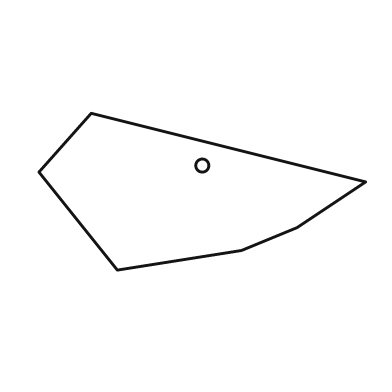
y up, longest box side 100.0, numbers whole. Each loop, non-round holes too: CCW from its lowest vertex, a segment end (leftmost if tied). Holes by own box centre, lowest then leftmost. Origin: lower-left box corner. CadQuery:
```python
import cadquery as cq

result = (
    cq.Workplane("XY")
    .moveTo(24.0, 0.0)
    .lineTo(62.0, 6.0)
    .lineTo(79.0, 13.0)
    .lineTo(100.0, 27.0)
    .lineTo(16.0, 48.0)
    .lineTo(0.0, 30.0)
    .close()
    .moveTo(50.0, 32.0)
    .circle(2.0)
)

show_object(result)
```